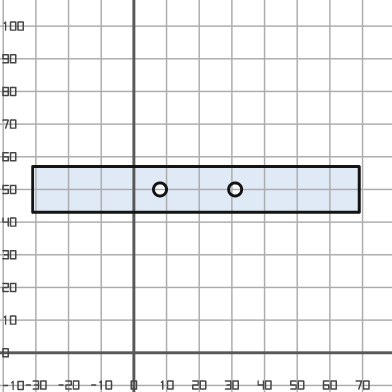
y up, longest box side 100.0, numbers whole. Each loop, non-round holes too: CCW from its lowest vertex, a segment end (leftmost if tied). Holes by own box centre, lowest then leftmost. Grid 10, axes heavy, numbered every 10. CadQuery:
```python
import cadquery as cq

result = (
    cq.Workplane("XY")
    .moveTo(-31.0, 43.0)
    .lineTo(69.0, 43.0)
    .lineTo(69.0, 57.0)
    .lineTo(-31.0, 57.0)
    .close()
    .moveTo(8.0, 50.0)
    .circle(2.0)
    .moveTo(31.0, 50.0)
    .circle(2.0)
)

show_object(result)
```